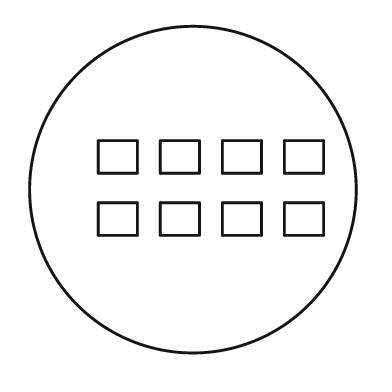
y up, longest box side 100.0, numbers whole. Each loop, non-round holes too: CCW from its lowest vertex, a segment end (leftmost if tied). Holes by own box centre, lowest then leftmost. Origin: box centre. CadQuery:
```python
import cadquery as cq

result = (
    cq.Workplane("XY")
    .moveTo(0.0, 0.0)
    .circle(50.0)
    .moveTo(-29.0, -14.0)
    .lineTo(-17.0, -14.0)
    .lineTo(-17.0, -4.0)
    .lineTo(-29.0, -4.0)
    .close()
    .moveTo(-10.0, -14.0)
    .lineTo(2.0, -14.0)
    .lineTo(2.0, -4.0)
    .lineTo(-10.0, -4.0)
    .close()
    .moveTo(9.0, -14.0)
    .lineTo(21.0, -14.0)
    .lineTo(21.0, -4.0)
    .lineTo(9.0, -4.0)
    .close()
    .moveTo(28.0, -14.0)
    .lineTo(40.0, -14.0)
    .lineTo(40.0, -4.0)
    .lineTo(28.0, -4.0)
    .close()
    .moveTo(-29.0, 5.0)
    .lineTo(-17.0, 5.0)
    .lineTo(-17.0, 15.0)
    .lineTo(-29.0, 15.0)
    .close()
    .moveTo(-10.0, 5.0)
    .lineTo(2.0, 5.0)
    .lineTo(2.0, 15.0)
    .lineTo(-10.0, 15.0)
    .close()
    .moveTo(9.0, 5.0)
    .lineTo(21.0, 5.0)
    .lineTo(21.0, 15.0)
    .lineTo(9.0, 15.0)
    .close()
    .moveTo(28.0, 5.0)
    .lineTo(40.0, 5.0)
    .lineTo(40.0, 15.0)
    .lineTo(28.0, 15.0)
    .close()
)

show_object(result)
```